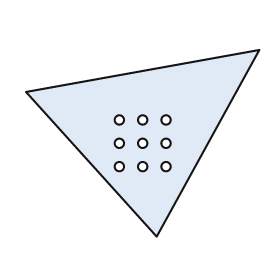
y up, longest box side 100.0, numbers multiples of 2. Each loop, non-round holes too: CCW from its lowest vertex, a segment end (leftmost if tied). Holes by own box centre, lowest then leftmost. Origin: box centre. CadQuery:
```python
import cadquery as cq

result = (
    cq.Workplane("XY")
    .moveTo(6.0, -40.0)
    .lineTo(50.0, 40.0)
    .lineTo(-50.0, 22.0)
    .close()
    .moveTo(-10.0, -10.0)
    .circle(2.0)
    .moveTo(0.0, -10.0)
    .circle(2.0)
    .moveTo(10.0, -10.0)
    .circle(2.0)
    .moveTo(-10.0, 0.0)
    .circle(2.0)
    .moveTo(0.0, 0.0)
    .circle(2.0)
    .moveTo(10.0, 0.0)
    .circle(2.0)
    .moveTo(-10.0, 10.0)
    .circle(2.0)
    .moveTo(0.0, 10.0)
    .circle(2.0)
    .moveTo(10.0, 10.0)
    .circle(2.0)
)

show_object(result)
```